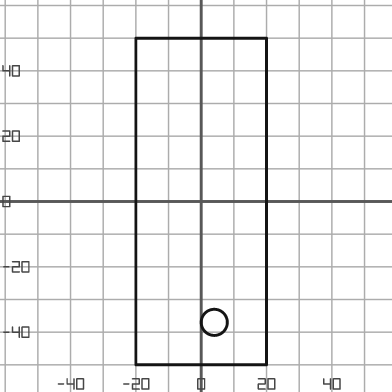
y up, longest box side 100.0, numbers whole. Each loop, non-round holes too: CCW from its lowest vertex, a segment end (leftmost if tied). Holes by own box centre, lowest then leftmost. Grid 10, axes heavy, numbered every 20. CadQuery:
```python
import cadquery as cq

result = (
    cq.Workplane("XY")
    .moveTo(-20.0, -50.0)
    .lineTo(20.0, -50.0)
    .lineTo(20.0, 50.0)
    .lineTo(-20.0, 50.0)
    .close()
    .moveTo(4.0, -37.0)
    .circle(4.0)
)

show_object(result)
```